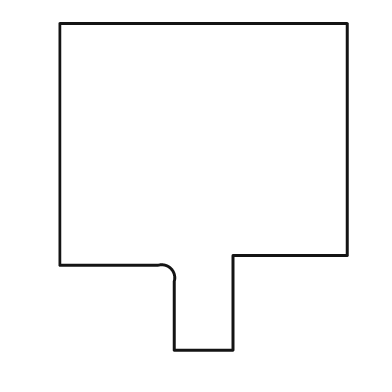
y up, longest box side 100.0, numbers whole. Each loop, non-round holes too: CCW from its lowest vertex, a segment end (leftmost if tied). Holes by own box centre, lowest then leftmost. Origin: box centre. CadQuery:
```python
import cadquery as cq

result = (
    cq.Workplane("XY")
    .moveTo(-9.0, -50.0)
    .lineTo(9.0, -50.0)
    .lineTo(9.0, -21.0)
    .lineTo(44.0, -21.0)
    .lineTo(44.0, 50.0)
    .lineTo(-44.0, 50.0)
    .lineTo(-44.0, -24.0)
    .lineTo(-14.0, -24.0)
    .threePointArc((-10.0, -25.0), (-9.0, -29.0))
    .close()
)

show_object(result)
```